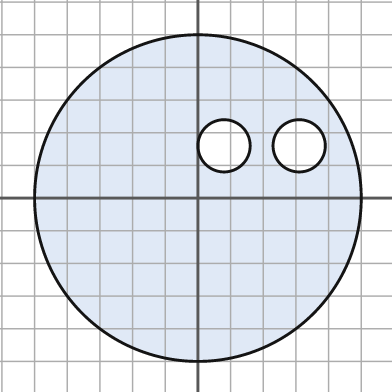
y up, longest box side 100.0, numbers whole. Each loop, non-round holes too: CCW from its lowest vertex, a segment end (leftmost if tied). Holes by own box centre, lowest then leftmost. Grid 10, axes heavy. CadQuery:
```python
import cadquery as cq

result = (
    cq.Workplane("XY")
    .moveTo(0.0, 0.0)
    .circle(50.0)
    .moveTo(8.0, 16.0)
    .circle(8.0)
    .moveTo(31.0, 16.0)
    .circle(8.0)
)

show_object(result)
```